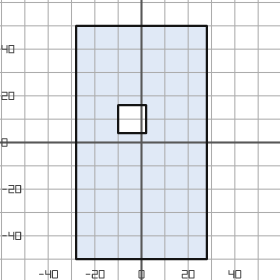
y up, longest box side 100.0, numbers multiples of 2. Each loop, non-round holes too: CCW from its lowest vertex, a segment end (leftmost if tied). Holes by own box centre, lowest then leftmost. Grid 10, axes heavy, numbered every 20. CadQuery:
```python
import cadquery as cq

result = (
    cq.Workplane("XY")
    .moveTo(-28.0, -50.0)
    .lineTo(28.0, -50.0)
    .lineTo(28.0, 50.0)
    .lineTo(-28.0, 50.0)
    .close()
    .moveTo(-10.0, 4.0)
    .lineTo(2.0, 4.0)
    .lineTo(2.0, 16.0)
    .lineTo(-10.0, 16.0)
    .close()
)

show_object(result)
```